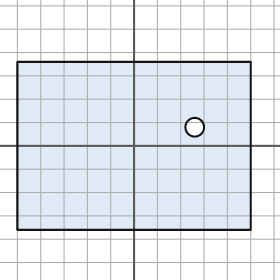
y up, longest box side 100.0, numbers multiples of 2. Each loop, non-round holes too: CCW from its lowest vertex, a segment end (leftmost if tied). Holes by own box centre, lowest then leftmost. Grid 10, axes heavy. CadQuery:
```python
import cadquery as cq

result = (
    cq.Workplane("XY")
    .moveTo(-50.0, -36.0)
    .lineTo(50.0, -36.0)
    .lineTo(50.0, 36.0)
    .lineTo(-50.0, 36.0)
    .close()
    .moveTo(26.0, 8.0)
    .circle(4.0)
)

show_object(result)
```